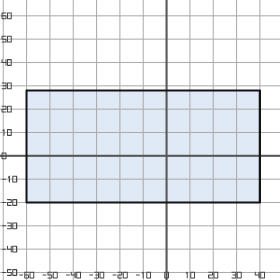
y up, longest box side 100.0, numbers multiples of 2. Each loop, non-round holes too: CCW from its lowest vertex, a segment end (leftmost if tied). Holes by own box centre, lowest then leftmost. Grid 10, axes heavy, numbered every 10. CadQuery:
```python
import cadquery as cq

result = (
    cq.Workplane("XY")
    .moveTo(-60.0, -20.0)
    .lineTo(40.0, -20.0)
    .lineTo(40.0, 28.0)
    .lineTo(-60.0, 28.0)
    .close()
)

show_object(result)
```